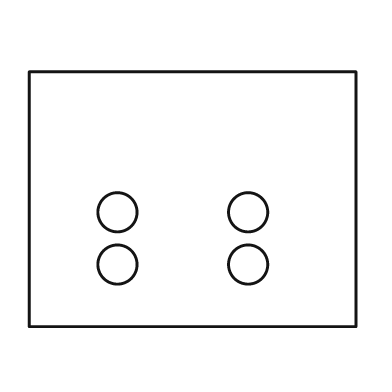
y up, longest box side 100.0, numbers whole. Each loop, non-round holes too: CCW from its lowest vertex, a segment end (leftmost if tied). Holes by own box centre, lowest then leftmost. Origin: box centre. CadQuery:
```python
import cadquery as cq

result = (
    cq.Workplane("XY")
    .moveTo(-50.0, -39.0)
    .lineTo(50.0, -39.0)
    .lineTo(50.0, 39.0)
    .lineTo(-50.0, 39.0)
    .close()
    .moveTo(-23.0, -20.0)
    .circle(6.0)
    .moveTo(17.0, -20.0)
    .circle(6.0)
    .moveTo(-23.0, -4.0)
    .circle(6.0)
    .moveTo(17.0, -4.0)
    .circle(6.0)
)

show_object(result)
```